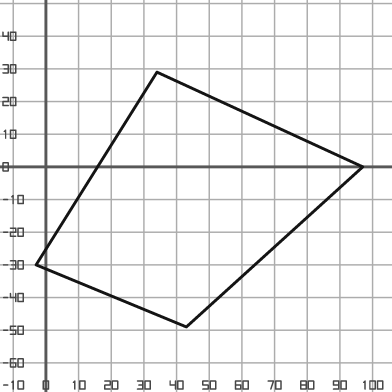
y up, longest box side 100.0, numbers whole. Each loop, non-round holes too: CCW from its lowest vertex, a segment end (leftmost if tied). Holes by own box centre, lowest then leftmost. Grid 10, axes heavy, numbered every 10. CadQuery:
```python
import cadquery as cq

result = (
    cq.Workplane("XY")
    .moveTo(43.0, -49.0)
    .lineTo(97.0, 0.0)
    .lineTo(34.0, 29.0)
    .lineTo(-3.0, -30.0)
    .close()
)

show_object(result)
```